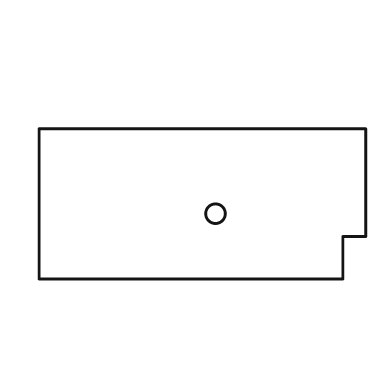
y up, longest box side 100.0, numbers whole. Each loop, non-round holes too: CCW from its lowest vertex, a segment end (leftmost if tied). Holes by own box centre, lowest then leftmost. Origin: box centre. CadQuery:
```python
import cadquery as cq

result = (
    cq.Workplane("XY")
    .moveTo(-50.0, -23.0)
    .lineTo(43.0, -23.0)
    .lineTo(43.0, -10.0)
    .lineTo(50.0, -10.0)
    .lineTo(50.0, 23.0)
    .lineTo(-50.0, 23.0)
    .close()
    .moveTo(4.0, -3.0)
    .circle(3.0)
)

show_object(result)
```